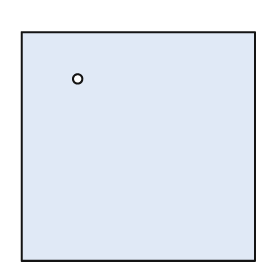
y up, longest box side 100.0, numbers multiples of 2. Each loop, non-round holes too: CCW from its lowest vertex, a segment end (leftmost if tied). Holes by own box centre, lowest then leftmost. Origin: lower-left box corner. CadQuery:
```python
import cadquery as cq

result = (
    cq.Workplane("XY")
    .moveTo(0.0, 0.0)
    .lineTo(100.0, 0.0)
    .lineTo(100.0, 98.0)
    .lineTo(0.0, 98.0)
    .close()
    .moveTo(24.0, 78.0)
    .circle(2.0)
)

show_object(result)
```